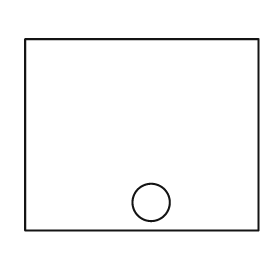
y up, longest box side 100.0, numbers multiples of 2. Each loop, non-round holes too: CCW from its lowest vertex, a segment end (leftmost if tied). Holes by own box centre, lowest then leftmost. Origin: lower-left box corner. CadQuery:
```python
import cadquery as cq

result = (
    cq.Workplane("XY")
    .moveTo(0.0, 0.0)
    .lineTo(100.0, 0.0)
    .lineTo(100.0, 82.0)
    .lineTo(0.0, 82.0)
    .close()
    .moveTo(54.0, 12.0)
    .circle(8.0)
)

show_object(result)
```